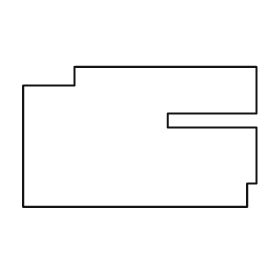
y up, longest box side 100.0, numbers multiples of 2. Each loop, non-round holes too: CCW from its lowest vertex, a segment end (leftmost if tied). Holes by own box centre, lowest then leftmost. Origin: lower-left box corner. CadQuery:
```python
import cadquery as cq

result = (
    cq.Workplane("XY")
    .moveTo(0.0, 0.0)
    .lineTo(96.0, 0.0)
    .lineTo(96.0, 10.0)
    .lineTo(100.0, 10.0)
    .lineTo(100.0, 34.0)
    .lineTo(62.0, 34.0)
    .lineTo(62.0, 40.0)
    .lineTo(100.0, 40.0)
    .lineTo(100.0, 60.0)
    .lineTo(22.0, 60.0)
    .lineTo(22.0, 52.0)
    .lineTo(0.0, 52.0)
    .close()
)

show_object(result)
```